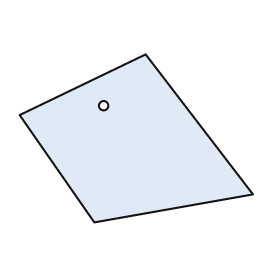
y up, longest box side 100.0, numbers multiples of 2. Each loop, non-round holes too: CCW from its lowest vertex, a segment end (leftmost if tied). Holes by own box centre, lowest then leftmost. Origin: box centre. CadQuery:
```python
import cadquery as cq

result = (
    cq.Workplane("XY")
    .moveTo(-18.0, -36.0)
    .lineTo(50.0, -24.0)
    .lineTo(4.0, 36.0)
    .lineTo(-50.0, 10.0)
    .close()
    .moveTo(-14.0, 14.0)
    .circle(2.0)
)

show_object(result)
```